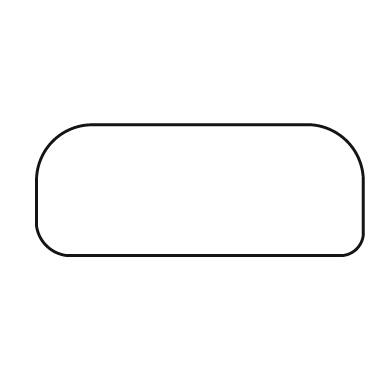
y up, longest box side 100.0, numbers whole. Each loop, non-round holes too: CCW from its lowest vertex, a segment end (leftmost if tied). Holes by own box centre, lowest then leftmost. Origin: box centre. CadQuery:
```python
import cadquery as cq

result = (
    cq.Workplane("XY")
    .moveTo(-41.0, -20.0)
    .lineTo(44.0, -20.0)
    .threePointArc((48.0, -18.0), (50.0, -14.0))
    .lineTo(50.0, 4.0)
    .threePointArc((45.0, 15.0), (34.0, 20.0))
    .lineTo(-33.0, 20.0)
    .threePointArc((-45.0, 15.0), (-50.0, 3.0))
    .lineTo(-50.0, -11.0)
    .threePointArc((-47.0, -17.0), (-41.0, -20.0))
    .close()
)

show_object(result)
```